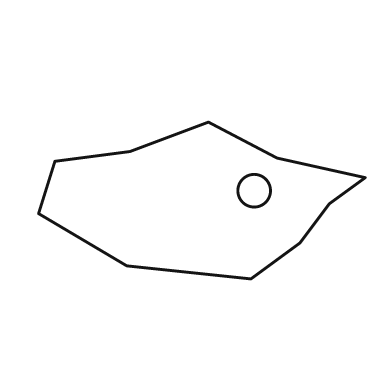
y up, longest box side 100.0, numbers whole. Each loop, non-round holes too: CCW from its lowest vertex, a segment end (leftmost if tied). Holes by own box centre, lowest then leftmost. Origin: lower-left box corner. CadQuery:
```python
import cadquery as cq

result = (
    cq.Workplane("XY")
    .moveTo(65.0, 0.0)
    .lineTo(80.0, 11.0)
    .lineTo(89.0, 23.0)
    .lineTo(100.0, 31.0)
    .lineTo(73.0, 37.0)
    .lineTo(52.0, 48.0)
    .lineTo(28.0, 39.0)
    .lineTo(5.0, 36.0)
    .lineTo(0.0, 20.0)
    .lineTo(27.0, 4.0)
    .close()
    .moveTo(66.0, 27.0)
    .circle(5.0)
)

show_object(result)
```